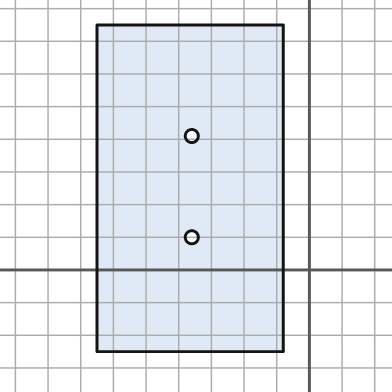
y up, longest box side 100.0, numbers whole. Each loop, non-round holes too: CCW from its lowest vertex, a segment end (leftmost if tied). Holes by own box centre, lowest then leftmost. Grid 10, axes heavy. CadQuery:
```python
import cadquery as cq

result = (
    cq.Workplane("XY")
    .moveTo(-65.0, -25.0)
    .lineTo(-8.0, -25.0)
    .lineTo(-8.0, 75.0)
    .lineTo(-65.0, 75.0)
    .close()
    .moveTo(-36.0, 10.0)
    .circle(2.0)
    .moveTo(-36.0, 41.0)
    .circle(2.0)
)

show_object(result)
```